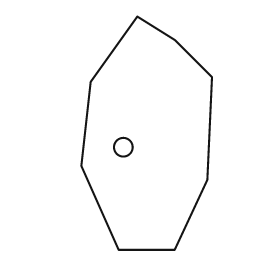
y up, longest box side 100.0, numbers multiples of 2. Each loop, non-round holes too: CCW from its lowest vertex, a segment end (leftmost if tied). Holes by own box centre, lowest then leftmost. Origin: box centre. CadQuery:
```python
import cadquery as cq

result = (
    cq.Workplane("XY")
    .moveTo(-12.0, -50.0)
    .lineTo(12.0, -50.0)
    .lineTo(26.0, -20.0)
    .lineTo(28.0, 24.0)
    .lineTo(12.0, 40.0)
    .lineTo(-4.0, 50.0)
    .lineTo(-24.0, 22.0)
    .lineTo(-28.0, -14.0)
    .close()
    .moveTo(-10.0, -6.0)
    .circle(4.0)
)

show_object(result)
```